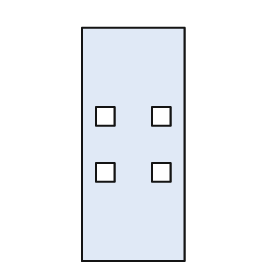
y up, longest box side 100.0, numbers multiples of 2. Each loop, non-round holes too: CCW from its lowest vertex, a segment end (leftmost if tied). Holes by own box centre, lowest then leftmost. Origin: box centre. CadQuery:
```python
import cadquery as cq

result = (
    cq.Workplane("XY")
    .moveTo(-22.0, -50.0)
    .lineTo(22.0, -50.0)
    .lineTo(22.0, 50.0)
    .lineTo(-22.0, 50.0)
    .close()
    .moveTo(-16.0, -16.0)
    .lineTo(-8.0, -16.0)
    .lineTo(-8.0, -8.0)
    .lineTo(-16.0, -8.0)
    .close()
    .moveTo(8.0, -16.0)
    .lineTo(16.0, -16.0)
    .lineTo(16.0, -8.0)
    .lineTo(8.0, -8.0)
    .close()
    .moveTo(-16.0, 8.0)
    .lineTo(-8.0, 8.0)
    .lineTo(-8.0, 16.0)
    .lineTo(-16.0, 16.0)
    .close()
    .moveTo(8.0, 8.0)
    .lineTo(16.0, 8.0)
    .lineTo(16.0, 16.0)
    .lineTo(8.0, 16.0)
    .close()
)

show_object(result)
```